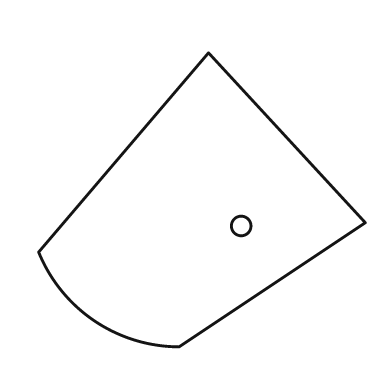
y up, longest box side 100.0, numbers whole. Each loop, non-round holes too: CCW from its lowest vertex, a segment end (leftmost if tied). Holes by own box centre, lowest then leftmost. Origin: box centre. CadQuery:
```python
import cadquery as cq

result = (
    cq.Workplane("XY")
    .moveTo(-7.0, -45.0)
    .lineTo(50.0, -7.0)
    .lineTo(2.0, 45.0)
    .lineTo(-50.0, -16.0)
    .threePointArc((-33.0, -37.0), (-7.0, -45.0))
    .close()
    .moveTo(12.0, -8.0)
    .circle(3.0)
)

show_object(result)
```